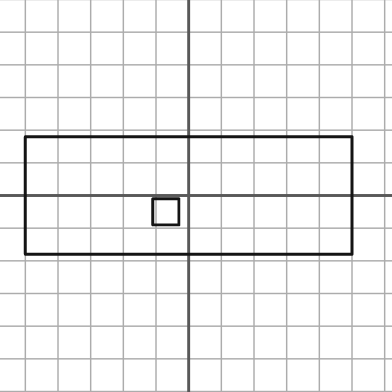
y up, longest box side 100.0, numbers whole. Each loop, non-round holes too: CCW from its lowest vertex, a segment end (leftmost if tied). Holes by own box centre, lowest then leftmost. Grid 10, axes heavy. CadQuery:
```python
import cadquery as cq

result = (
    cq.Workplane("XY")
    .moveTo(-50.0, -18.0)
    .lineTo(50.0, -18.0)
    .lineTo(50.0, 18.0)
    .lineTo(-50.0, 18.0)
    .close()
    .moveTo(-11.0, -9.0)
    .lineTo(-3.0, -9.0)
    .lineTo(-3.0, -1.0)
    .lineTo(-11.0, -1.0)
    .close()
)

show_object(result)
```